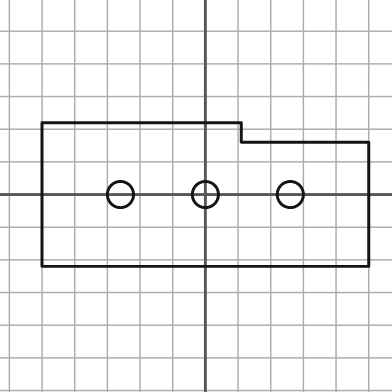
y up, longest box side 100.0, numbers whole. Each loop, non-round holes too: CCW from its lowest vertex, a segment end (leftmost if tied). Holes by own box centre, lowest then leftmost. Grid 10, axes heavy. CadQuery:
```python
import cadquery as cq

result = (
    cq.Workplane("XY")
    .moveTo(-50.0, -22.0)
    .lineTo(50.0, -22.0)
    .lineTo(50.0, 16.0)
    .lineTo(11.0, 16.0)
    .lineTo(11.0, 22.0)
    .lineTo(-50.0, 22.0)
    .close()
    .moveTo(-26.0, 0.0)
    .circle(4.0)
    .moveTo(0.0, 0.0)
    .circle(4.0)
    .moveTo(26.0, 0.0)
    .circle(4.0)
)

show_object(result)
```